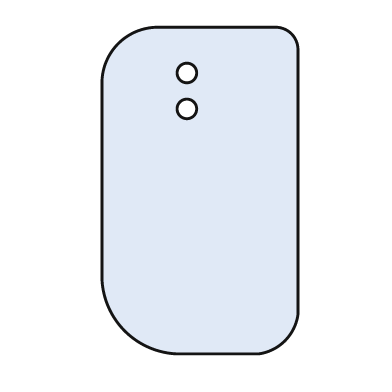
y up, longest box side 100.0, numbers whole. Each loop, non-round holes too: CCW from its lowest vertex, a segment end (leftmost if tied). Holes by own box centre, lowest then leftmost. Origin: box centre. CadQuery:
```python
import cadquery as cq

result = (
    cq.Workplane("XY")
    .moveTo(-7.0, -50.0)
    .lineTo(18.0, -50.0)
    .threePointArc((26.0, -46.0), (30.0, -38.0))
    .lineTo(30.0, 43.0)
    .threePointArc((28.0, 48.0), (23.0, 50.0))
    .lineTo(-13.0, 50.0)
    .threePointArc((-25.0, 45.0), (-30.0, 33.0))
    .lineTo(-30.0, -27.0)
    .threePointArc((-23.0, -43.0), (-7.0, -50.0))
    .close()
    .moveTo(-4.0, 25.0)
    .circle(3.0)
    .moveTo(-4.0, 36.0)
    .circle(3.0)
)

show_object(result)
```